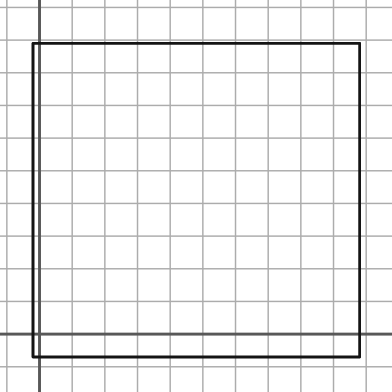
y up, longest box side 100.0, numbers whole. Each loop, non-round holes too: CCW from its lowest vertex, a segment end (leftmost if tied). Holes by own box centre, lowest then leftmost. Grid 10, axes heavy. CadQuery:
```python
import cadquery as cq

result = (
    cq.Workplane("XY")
    .moveTo(-2.0, -7.0)
    .lineTo(98.0, -7.0)
    .lineTo(98.0, 89.0)
    .lineTo(-2.0, 89.0)
    .close()
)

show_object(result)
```